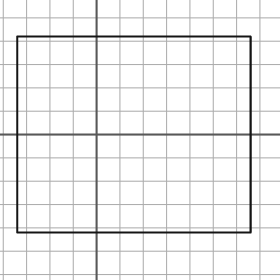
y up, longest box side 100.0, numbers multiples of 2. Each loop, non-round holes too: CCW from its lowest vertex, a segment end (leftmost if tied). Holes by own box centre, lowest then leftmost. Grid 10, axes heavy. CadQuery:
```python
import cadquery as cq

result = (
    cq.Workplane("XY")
    .moveTo(-34.0, -42.0)
    .lineTo(66.0, -42.0)
    .lineTo(66.0, 42.0)
    .lineTo(-34.0, 42.0)
    .close()
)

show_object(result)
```